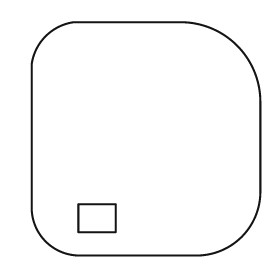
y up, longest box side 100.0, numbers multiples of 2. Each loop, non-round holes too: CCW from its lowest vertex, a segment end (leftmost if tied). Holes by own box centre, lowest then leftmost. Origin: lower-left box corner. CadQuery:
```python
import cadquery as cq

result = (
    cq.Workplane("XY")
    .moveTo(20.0, 0.0)
    .lineTo(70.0, 0.0)
    .threePointArc((90.0, 8.0), (98.0, 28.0))
    .lineTo(98.0, 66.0)
    .threePointArc((88.0, 90.0), (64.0, 100.0))
    .lineTo(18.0, 100.0)
    .threePointArc((6.0, 94.0), (0.0, 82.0))
    .lineTo(0.0, 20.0)
    .threePointArc((6.0, 6.0), (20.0, 0.0))
    .close()
    .moveTo(20.0, 10.0)
    .lineTo(36.0, 10.0)
    .lineTo(36.0, 22.0)
    .lineTo(20.0, 22.0)
    .close()
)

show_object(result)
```